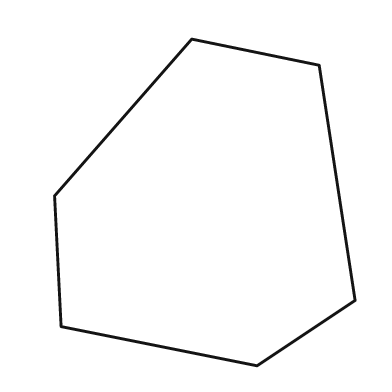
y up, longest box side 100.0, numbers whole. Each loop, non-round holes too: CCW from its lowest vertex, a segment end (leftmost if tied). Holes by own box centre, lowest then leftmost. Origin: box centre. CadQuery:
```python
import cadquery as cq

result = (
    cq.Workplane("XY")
    .moveTo(16.0, -50.0)
    .lineTo(46.0, -30.0)
    .lineTo(35.0, 42.0)
    .lineTo(-4.0, 50.0)
    .lineTo(-46.0, 2.0)
    .lineTo(-44.0, -38.0)
    .close()
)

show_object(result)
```